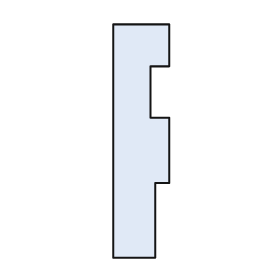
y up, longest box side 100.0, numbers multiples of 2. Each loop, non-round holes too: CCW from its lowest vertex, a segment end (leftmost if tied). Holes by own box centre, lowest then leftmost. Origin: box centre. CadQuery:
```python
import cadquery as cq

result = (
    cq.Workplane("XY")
    .moveTo(-12.0, -50.0)
    .lineTo(6.0, -50.0)
    .lineTo(6.0, -18.0)
    .lineTo(12.0, -18.0)
    .lineTo(12.0, 10.0)
    .lineTo(4.0, 10.0)
    .lineTo(4.0, 32.0)
    .lineTo(12.0, 32.0)
    .lineTo(12.0, 50.0)
    .lineTo(-12.0, 50.0)
    .close()
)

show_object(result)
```